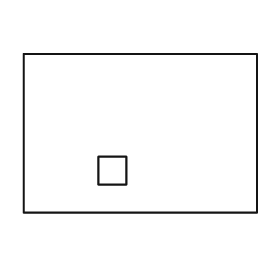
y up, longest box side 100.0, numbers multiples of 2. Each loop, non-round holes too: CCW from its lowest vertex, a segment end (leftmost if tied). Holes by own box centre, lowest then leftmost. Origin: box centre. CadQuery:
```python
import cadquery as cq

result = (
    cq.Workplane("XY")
    .moveTo(-50.0, -34.0)
    .lineTo(50.0, -34.0)
    .lineTo(50.0, 34.0)
    .lineTo(-50.0, 34.0)
    .close()
    .moveTo(-18.0, -22.0)
    .lineTo(-6.0, -22.0)
    .lineTo(-6.0, -10.0)
    .lineTo(-18.0, -10.0)
    .close()
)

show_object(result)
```